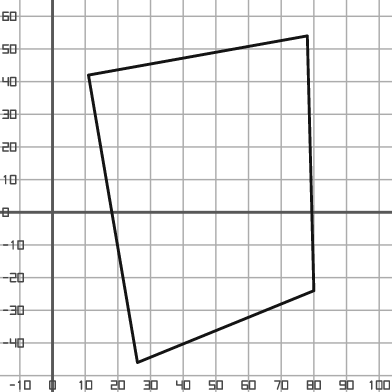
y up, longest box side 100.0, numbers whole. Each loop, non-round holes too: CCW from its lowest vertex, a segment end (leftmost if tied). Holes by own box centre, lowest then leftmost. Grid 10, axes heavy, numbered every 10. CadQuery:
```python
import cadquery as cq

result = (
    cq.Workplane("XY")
    .moveTo(26.0, -46.0)
    .lineTo(80.0, -24.0)
    .lineTo(78.0, 54.0)
    .lineTo(11.0, 42.0)
    .close()
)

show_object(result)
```